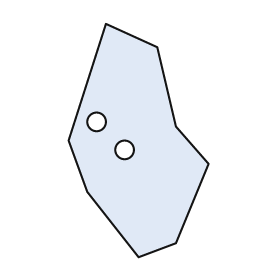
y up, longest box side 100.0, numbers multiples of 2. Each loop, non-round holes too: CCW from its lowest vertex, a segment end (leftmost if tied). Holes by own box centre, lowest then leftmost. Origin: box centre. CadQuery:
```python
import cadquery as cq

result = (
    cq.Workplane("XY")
    .moveTo(0.0, -50.0)
    .lineTo(16.0, -44.0)
    .lineTo(30.0, -10.0)
    .lineTo(16.0, 6.0)
    .lineTo(8.0, 40.0)
    .lineTo(-14.0, 50.0)
    .lineTo(-30.0, 0.0)
    .lineTo(-22.0, -22.0)
    .close()
    .moveTo(-6.0, -4.0)
    .circle(4.0)
    .moveTo(-18.0, 8.0)
    .circle(4.0)
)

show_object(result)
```